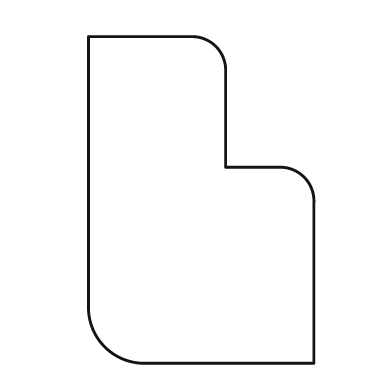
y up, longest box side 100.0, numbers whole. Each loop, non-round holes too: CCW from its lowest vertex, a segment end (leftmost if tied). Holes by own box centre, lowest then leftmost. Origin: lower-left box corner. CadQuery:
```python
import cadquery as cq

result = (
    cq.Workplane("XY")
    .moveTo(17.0, 0.0)
    .lineTo(69.0, 0.0)
    .lineTo(69.0, 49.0)
    .threePointArc((66.0, 57.0), (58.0, 60.0))
    .lineTo(42.0, 60.0)
    .lineTo(42.0, 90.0)
    .threePointArc((39.0, 97.0), (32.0, 100.0))
    .lineTo(0.0, 100.0)
    .lineTo(0.0, 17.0)
    .threePointArc((5.0, 5.0), (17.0, 0.0))
    .close()
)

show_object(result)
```